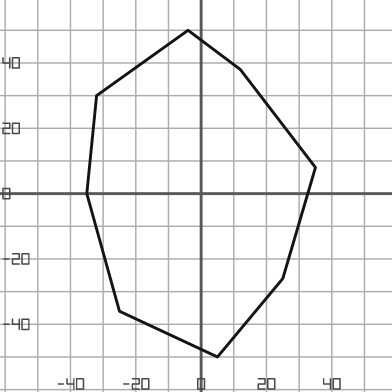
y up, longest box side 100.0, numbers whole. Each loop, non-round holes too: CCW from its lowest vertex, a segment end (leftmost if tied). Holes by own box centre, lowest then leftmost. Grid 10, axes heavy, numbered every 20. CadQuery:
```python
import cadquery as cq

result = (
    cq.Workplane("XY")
    .moveTo(5.0, -50.0)
    .lineTo(25.0, -26.0)
    .lineTo(35.0, 8.0)
    .lineTo(12.0, 38.0)
    .lineTo(-4.0, 50.0)
    .lineTo(-32.0, 30.0)
    .lineTo(-35.0, 0.0)
    .lineTo(-25.0, -36.0)
    .close()
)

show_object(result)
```